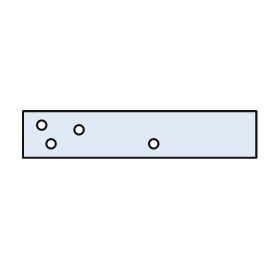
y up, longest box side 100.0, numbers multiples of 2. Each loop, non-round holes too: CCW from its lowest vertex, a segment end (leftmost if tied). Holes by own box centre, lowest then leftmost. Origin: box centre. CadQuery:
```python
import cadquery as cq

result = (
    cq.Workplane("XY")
    .moveTo(-50.0, -10.0)
    .lineTo(50.0, -10.0)
    .lineTo(50.0, 10.0)
    .lineTo(-50.0, 10.0)
    .close()
    .moveTo(-38.0, -4.0)
    .circle(2.0)
    .moveTo(6.0, -4.0)
    .circle(2.0)
    .moveTo(-26.0, 2.0)
    .circle(2.0)
    .moveTo(-42.0, 4.0)
    .circle(2.0)
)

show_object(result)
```